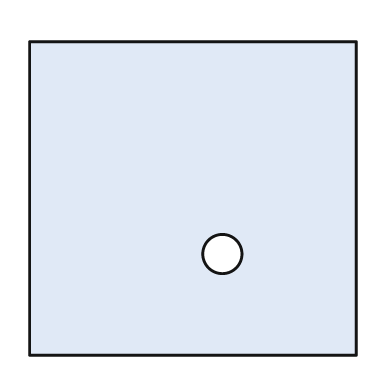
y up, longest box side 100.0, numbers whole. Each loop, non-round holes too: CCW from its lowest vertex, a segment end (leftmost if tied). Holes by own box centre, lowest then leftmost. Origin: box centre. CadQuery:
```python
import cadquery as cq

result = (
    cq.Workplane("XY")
    .moveTo(-50.0, -48.0)
    .lineTo(50.0, -48.0)
    .lineTo(50.0, 48.0)
    .lineTo(-50.0, 48.0)
    .close()
    .moveTo(9.0, -17.0)
    .circle(6.0)
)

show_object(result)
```